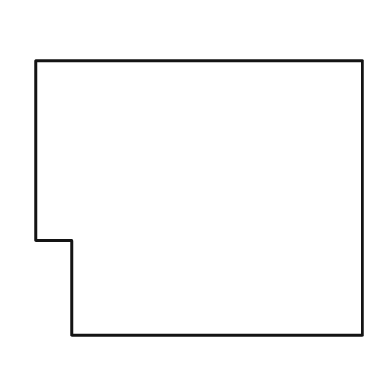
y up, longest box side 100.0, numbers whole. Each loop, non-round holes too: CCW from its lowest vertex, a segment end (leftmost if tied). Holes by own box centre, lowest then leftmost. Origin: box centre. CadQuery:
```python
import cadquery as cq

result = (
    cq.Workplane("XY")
    .moveTo(-39.0, -42.0)
    .lineTo(50.0, -42.0)
    .lineTo(50.0, 42.0)
    .lineTo(-50.0, 42.0)
    .lineTo(-50.0, -13.0)
    .lineTo(-39.0, -13.0)
    .close()
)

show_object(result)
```